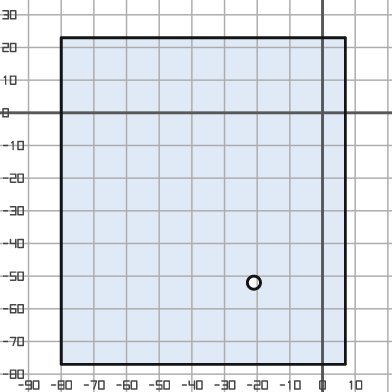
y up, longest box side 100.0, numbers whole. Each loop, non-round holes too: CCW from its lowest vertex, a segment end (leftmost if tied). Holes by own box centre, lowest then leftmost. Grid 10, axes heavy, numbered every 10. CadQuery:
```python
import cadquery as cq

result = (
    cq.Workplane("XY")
    .moveTo(-80.0, -77.0)
    .lineTo(7.0, -77.0)
    .lineTo(7.0, 23.0)
    .lineTo(-80.0, 23.0)
    .close()
    .moveTo(-21.0, -52.0)
    .circle(2.0)
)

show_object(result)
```